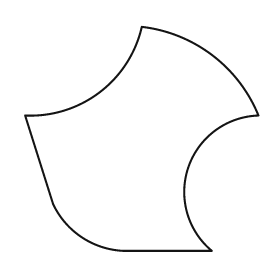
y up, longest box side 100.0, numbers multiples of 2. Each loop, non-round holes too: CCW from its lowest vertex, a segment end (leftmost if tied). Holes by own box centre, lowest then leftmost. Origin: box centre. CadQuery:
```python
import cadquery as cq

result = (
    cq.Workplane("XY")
    .moveTo(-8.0, -48.0)
    .lineTo(30.0, -48.0)
    .threePointArc((20.0, -12.0), (50.0, 10.0))
    .threePointArc((30.0, 36.0), (0.0, 48.0))
    .threePointArc((-18.0, 20.0), (-50.0, 10.0))
    .lineTo(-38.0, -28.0)
    .threePointArc((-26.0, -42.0), (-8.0, -48.0))
    .close()
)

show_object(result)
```